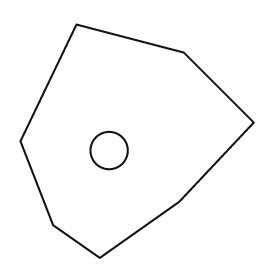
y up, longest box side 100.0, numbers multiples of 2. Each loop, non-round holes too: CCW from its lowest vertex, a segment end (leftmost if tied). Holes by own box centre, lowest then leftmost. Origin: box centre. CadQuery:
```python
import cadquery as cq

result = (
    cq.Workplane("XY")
    .moveTo(-16.0, -50.0)
    .lineTo(18.0, -26.0)
    .lineTo(50.0, 8.0)
    .lineTo(20.0, 38.0)
    .lineTo(-26.0, 50.0)
    .lineTo(-50.0, 0.0)
    .lineTo(-36.0, -36.0)
    .close()
    .moveTo(-12.0, -4.0)
    .circle(8.0)
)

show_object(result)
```